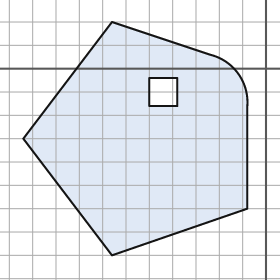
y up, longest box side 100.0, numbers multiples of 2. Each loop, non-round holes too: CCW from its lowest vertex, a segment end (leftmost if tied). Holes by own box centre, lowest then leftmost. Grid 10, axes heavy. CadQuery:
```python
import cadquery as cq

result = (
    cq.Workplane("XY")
    .moveTo(-66.0, -80.0)
    .lineTo(-8.0, -60.0)
    .lineTo(-8.0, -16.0)
    .threePointArc((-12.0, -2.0), (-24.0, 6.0))
    .lineTo(-66.0, 20.0)
    .lineTo(-104.0, -30.0)
    .close()
    .moveTo(-50.0, -16.0)
    .lineTo(-38.0, -16.0)
    .lineTo(-38.0, -4.0)
    .lineTo(-50.0, -4.0)
    .close()
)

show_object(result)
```